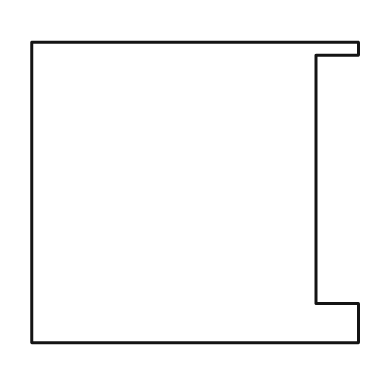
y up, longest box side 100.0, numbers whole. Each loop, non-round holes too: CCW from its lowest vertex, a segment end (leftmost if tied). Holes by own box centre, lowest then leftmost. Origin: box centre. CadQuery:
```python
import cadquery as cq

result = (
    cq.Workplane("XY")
    .moveTo(-50.0, -46.0)
    .lineTo(50.0, -46.0)
    .lineTo(50.0, -34.0)
    .lineTo(37.0, -34.0)
    .lineTo(37.0, 42.0)
    .lineTo(50.0, 42.0)
    .lineTo(50.0, 46.0)
    .lineTo(-50.0, 46.0)
    .close()
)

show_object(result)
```